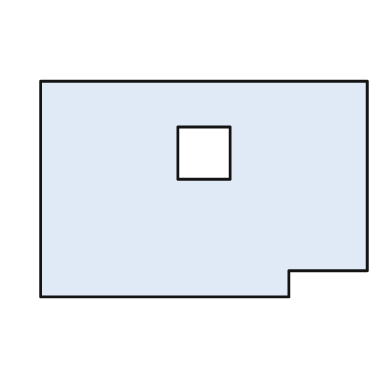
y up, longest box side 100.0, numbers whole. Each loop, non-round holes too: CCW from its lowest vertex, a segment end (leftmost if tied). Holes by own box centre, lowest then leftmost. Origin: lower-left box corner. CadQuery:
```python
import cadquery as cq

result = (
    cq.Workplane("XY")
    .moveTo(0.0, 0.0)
    .lineTo(76.0, 0.0)
    .lineTo(76.0, 8.0)
    .lineTo(100.0, 8.0)
    .lineTo(100.0, 66.0)
    .lineTo(0.0, 66.0)
    .close()
    .moveTo(42.0, 36.0)
    .lineTo(58.0, 36.0)
    .lineTo(58.0, 52.0)
    .lineTo(42.0, 52.0)
    .close()
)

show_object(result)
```